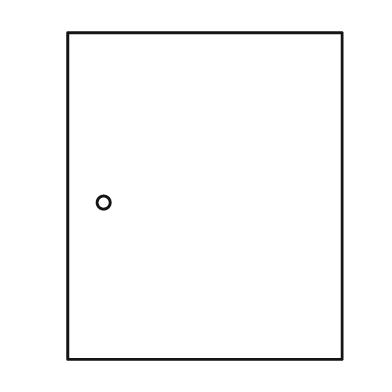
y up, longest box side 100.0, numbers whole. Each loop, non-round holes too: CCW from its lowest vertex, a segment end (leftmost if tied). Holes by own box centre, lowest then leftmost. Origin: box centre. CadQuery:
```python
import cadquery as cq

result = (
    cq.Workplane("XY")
    .moveTo(-42.0, -50.0)
    .lineTo(42.0, -50.0)
    .lineTo(42.0, 50.0)
    .lineTo(-42.0, 50.0)
    .close()
    .moveTo(-31.0, -2.0)
    .circle(2.0)
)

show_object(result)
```